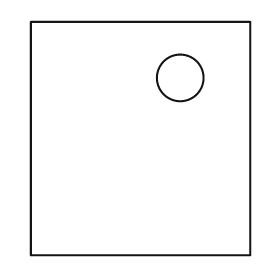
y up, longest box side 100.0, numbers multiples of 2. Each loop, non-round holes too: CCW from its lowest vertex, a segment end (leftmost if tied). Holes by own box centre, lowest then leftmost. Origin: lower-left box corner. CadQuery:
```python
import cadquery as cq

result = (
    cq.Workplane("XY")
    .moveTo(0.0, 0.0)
    .lineTo(94.0, 0.0)
    .lineTo(94.0, 100.0)
    .lineTo(0.0, 100.0)
    .close()
    .moveTo(64.0, 76.0)
    .circle(10.0)
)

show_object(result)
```